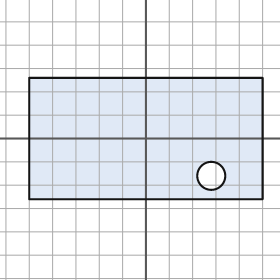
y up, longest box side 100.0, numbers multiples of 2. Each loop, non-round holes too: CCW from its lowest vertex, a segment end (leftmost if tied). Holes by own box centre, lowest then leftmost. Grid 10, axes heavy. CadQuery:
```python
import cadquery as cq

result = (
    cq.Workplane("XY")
    .moveTo(-50.0, -26.0)
    .lineTo(50.0, -26.0)
    .lineTo(50.0, 26.0)
    .lineTo(-50.0, 26.0)
    .close()
    .moveTo(28.0, -16.0)
    .circle(6.0)
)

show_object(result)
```